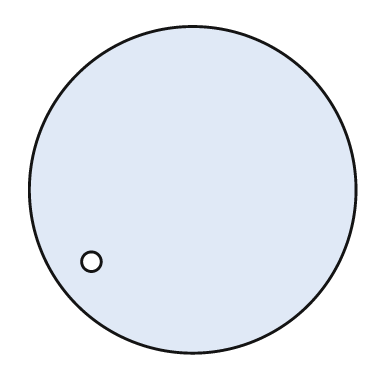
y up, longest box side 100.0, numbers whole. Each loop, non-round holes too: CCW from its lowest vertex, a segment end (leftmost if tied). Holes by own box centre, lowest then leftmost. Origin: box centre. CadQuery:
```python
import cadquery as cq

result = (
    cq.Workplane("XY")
    .moveTo(0.0, 0.0)
    .circle(50.0)
    .moveTo(-31.0, -22.0)
    .circle(3.0)
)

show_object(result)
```